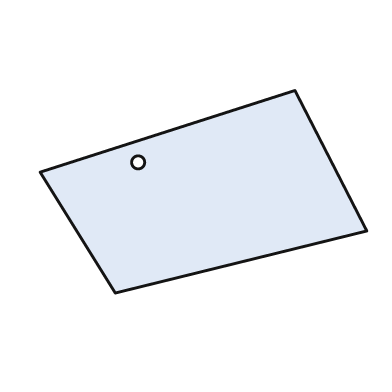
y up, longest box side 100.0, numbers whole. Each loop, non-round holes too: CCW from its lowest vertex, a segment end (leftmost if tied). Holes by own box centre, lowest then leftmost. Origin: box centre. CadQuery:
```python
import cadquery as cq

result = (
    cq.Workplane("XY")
    .moveTo(-27.0, -31.0)
    .lineTo(50.0, -12.0)
    .lineTo(28.0, 31.0)
    .lineTo(-50.0, 6.0)
    .close()
    .moveTo(-20.0, 9.0)
    .circle(2.0)
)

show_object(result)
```